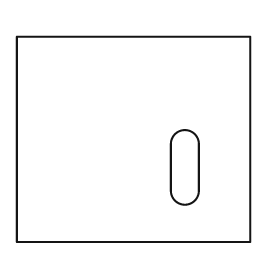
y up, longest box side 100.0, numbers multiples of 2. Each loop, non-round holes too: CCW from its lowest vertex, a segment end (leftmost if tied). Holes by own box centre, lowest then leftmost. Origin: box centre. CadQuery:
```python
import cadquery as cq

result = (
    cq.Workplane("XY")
    .moveTo(-50.0, -44.0)
    .lineTo(50.0, -44.0)
    .lineTo(50.0, 44.0)
    .lineTo(-50.0, 44.0)
    .close()
    .moveTo(16.0, -22.0)
    .threePointArc((22.0, -28.0), (28.0, -22.0))
    .lineTo(28.0, -2.0)
    .threePointArc((22.0, 4.0), (16.0, -2.0))
    .close()
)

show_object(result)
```